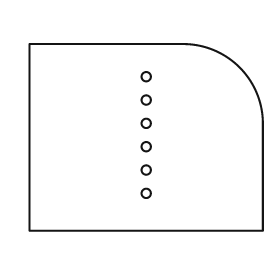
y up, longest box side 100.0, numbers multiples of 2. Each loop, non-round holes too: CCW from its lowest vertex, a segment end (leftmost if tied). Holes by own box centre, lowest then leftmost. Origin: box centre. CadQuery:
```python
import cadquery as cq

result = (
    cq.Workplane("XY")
    .moveTo(-50.0, -40.0)
    .lineTo(50.0, -40.0)
    .lineTo(50.0, 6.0)
    .threePointArc((40.0, 30.0), (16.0, 40.0))
    .lineTo(-50.0, 40.0)
    .close()
    .moveTo(0.0, -24.0)
    .circle(2.0)
    .moveTo(0.0, -14.0)
    .circle(2.0)
    .moveTo(0.0, -4.0)
    .circle(2.0)
    .moveTo(0.0, 6.0)
    .circle(2.0)
    .moveTo(0.0, 16.0)
    .circle(2.0)
    .moveTo(0.0, 26.0)
    .circle(2.0)
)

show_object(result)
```